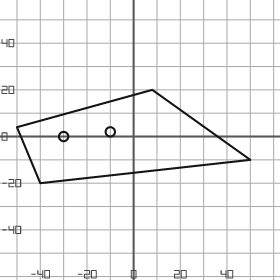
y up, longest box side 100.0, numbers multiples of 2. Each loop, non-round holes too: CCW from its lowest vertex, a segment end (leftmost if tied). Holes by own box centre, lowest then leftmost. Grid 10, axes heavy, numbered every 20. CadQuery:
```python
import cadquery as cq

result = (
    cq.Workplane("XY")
    .moveTo(-40.0, -20.0)
    .lineTo(50.0, -10.0)
    .lineTo(8.0, 20.0)
    .lineTo(-50.0, 4.0)
    .close()
    .moveTo(-30.0, 0.0)
    .circle(2.0)
    .moveTo(-10.0, 2.0)
    .circle(2.0)
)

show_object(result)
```